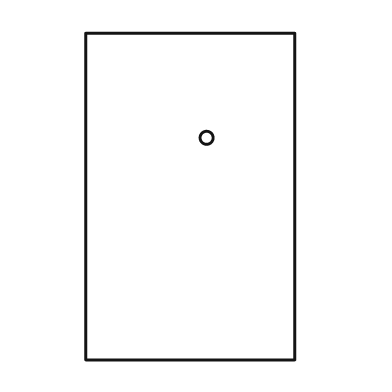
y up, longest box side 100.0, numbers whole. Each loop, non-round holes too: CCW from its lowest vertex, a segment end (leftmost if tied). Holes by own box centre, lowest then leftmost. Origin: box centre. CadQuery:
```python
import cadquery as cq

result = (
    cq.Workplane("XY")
    .moveTo(-32.0, -50.0)
    .lineTo(32.0, -50.0)
    .lineTo(32.0, 50.0)
    .lineTo(-32.0, 50.0)
    .close()
    .moveTo(5.0, 18.0)
    .circle(2.0)
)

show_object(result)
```